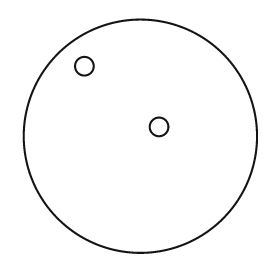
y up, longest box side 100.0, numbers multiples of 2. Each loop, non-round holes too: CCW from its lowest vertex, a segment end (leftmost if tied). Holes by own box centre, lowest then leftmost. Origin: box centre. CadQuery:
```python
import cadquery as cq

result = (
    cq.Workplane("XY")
    .moveTo(0.0, 0.0)
    .circle(50.0)
    .moveTo(8.0, 4.0)
    .circle(4.0)
    .moveTo(-24.0, 30.0)
    .circle(4.0)
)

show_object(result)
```